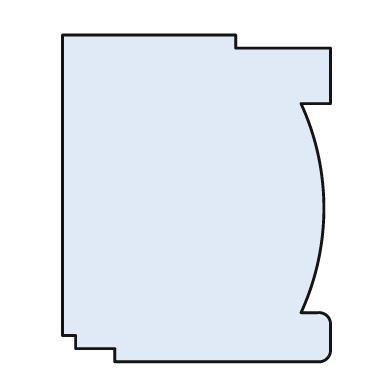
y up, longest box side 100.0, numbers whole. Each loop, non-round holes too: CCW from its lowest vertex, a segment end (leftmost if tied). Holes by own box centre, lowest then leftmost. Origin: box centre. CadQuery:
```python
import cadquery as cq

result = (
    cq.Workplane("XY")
    .moveTo(-25.0, -50.0)
    .lineTo(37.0, -50.0)
    .threePointArc((40.0, -49.0), (41.0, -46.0))
    .lineTo(41.0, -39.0)
    .threePointArc((40.0, -36.0), (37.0, -35.0))
    .lineTo(32.0, -35.0)
    .threePointArc((39.0, -3.0), (32.0, 29.0))
    .lineTo(41.0, 29.0)
    .lineTo(41.0, 46.0)
    .lineTo(12.0, 46.0)
    .lineTo(12.0, 50.0)
    .lineTo(-41.0, 50.0)
    .lineTo(-41.0, -42.0)
    .lineTo(-37.0, -42.0)
    .lineTo(-37.0, -46.0)
    .lineTo(-25.0, -46.0)
    .close()
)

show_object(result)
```